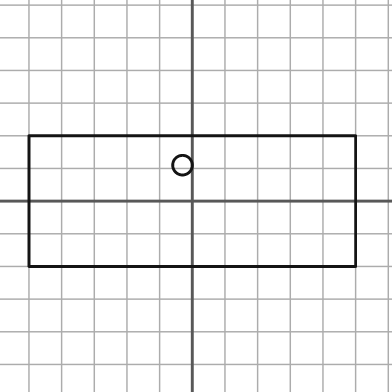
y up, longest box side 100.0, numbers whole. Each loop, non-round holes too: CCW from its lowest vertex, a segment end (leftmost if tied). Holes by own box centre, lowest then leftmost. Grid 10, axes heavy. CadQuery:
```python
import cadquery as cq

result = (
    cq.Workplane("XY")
    .moveTo(-50.0, -20.0)
    .lineTo(50.0, -20.0)
    .lineTo(50.0, 20.0)
    .lineTo(-50.0, 20.0)
    .close()
    .moveTo(-3.0, 11.0)
    .circle(3.0)
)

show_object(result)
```